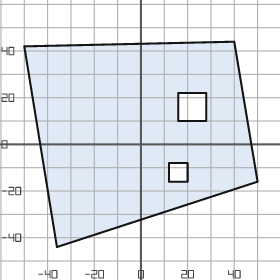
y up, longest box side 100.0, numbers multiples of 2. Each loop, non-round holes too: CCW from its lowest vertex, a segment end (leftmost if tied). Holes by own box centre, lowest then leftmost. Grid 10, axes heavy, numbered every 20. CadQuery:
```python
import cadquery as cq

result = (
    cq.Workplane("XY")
    .moveTo(-36.0, -44.0)
    .lineTo(50.0, -16.0)
    .lineTo(40.0, 44.0)
    .lineTo(-50.0, 42.0)
    .close()
    .moveTo(12.0, -16.0)
    .lineTo(20.0, -16.0)
    .lineTo(20.0, -8.0)
    .lineTo(12.0, -8.0)
    .close()
    .moveTo(16.0, 10.0)
    .lineTo(28.0, 10.0)
    .lineTo(28.0, 22.0)
    .lineTo(16.0, 22.0)
    .close()
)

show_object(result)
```